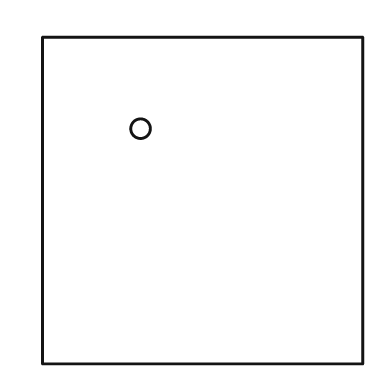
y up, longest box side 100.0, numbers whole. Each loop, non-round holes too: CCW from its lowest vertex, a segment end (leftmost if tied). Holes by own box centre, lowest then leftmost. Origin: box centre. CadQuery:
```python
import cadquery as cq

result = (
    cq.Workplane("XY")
    .moveTo(-49.0, -50.0)
    .lineTo(49.0, -50.0)
    .lineTo(49.0, 50.0)
    .lineTo(-49.0, 50.0)
    .close()
    .moveTo(-19.0, 22.0)
    .circle(3.0)
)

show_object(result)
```